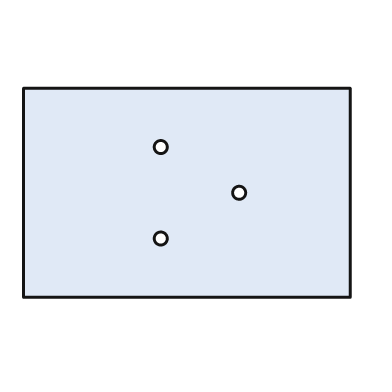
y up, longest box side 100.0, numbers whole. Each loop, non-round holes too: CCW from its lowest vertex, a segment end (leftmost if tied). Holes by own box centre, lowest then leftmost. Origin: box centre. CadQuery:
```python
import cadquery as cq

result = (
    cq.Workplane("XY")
    .moveTo(-50.0, -32.0)
    .lineTo(50.0, -32.0)
    .lineTo(50.0, 32.0)
    .lineTo(-50.0, 32.0)
    .close()
    .moveTo(-8.0, -14.0)
    .circle(2.0)
    .moveTo(16.0, 0.0)
    .circle(2.0)
    .moveTo(-8.0, 14.0)
    .circle(2.0)
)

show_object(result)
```